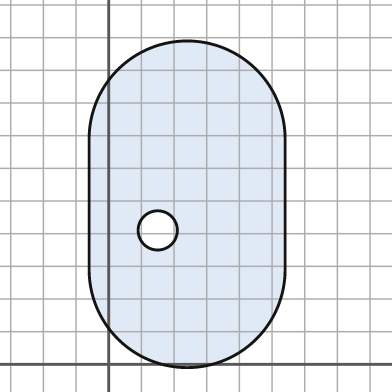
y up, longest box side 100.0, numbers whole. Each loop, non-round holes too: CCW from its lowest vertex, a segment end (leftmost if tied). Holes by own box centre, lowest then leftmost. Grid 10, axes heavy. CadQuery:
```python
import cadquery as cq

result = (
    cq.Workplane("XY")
    .moveTo(-6.0, 29.0)
    .threePointArc((24.0, -1.0), (54.0, 29.0))
    .lineTo(54.0, 69.0)
    .threePointArc((24.0, 99.0), (-6.0, 69.0))
    .close()
    .moveTo(15.0, 41.0)
    .circle(6.0)
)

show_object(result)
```